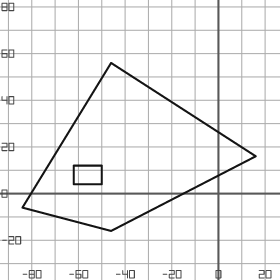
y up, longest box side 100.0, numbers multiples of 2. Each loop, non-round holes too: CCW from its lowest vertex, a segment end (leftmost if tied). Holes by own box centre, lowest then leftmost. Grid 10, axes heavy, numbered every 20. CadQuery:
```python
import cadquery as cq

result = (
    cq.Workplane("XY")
    .moveTo(-46.0, -16.0)
    .lineTo(16.0, 16.0)
    .lineTo(-46.0, 56.0)
    .lineTo(-84.0, -6.0)
    .close()
    .moveTo(-62.0, 4.0)
    .lineTo(-50.0, 4.0)
    .lineTo(-50.0, 12.0)
    .lineTo(-62.0, 12.0)
    .close()
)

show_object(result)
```